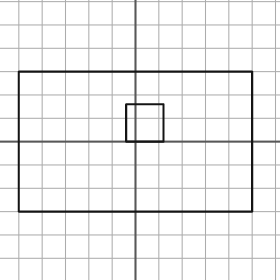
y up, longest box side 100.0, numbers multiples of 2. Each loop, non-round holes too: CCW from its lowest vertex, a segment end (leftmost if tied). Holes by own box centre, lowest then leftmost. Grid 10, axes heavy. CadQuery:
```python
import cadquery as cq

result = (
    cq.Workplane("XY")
    .moveTo(-50.0, -30.0)
    .lineTo(50.0, -30.0)
    .lineTo(50.0, 30.0)
    .lineTo(-50.0, 30.0)
    .close()
    .moveTo(-4.0, 0.0)
    .lineTo(12.0, 0.0)
    .lineTo(12.0, 16.0)
    .lineTo(-4.0, 16.0)
    .close()
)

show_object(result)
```